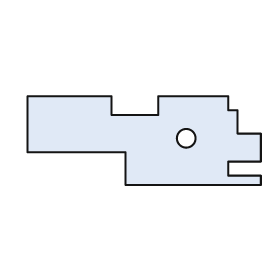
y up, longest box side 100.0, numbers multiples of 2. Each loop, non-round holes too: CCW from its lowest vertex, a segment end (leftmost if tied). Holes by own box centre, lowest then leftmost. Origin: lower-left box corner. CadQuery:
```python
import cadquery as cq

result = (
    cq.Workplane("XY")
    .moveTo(42.0, 0.0)
    .lineTo(100.0, 0.0)
    .lineTo(100.0, 4.0)
    .lineTo(86.0, 4.0)
    .lineTo(86.0, 10.0)
    .lineTo(100.0, 10.0)
    .lineTo(100.0, 22.0)
    .lineTo(90.0, 22.0)
    .lineTo(90.0, 32.0)
    .lineTo(86.0, 32.0)
    .lineTo(86.0, 38.0)
    .lineTo(56.0, 38.0)
    .lineTo(56.0, 30.0)
    .lineTo(36.0, 30.0)
    .lineTo(36.0, 38.0)
    .lineTo(0.0, 38.0)
    .lineTo(0.0, 14.0)
    .lineTo(42.0, 14.0)
    .close()
    .moveTo(68.0, 20.0)
    .circle(4.0)
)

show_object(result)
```